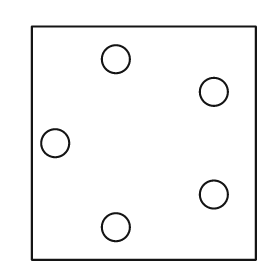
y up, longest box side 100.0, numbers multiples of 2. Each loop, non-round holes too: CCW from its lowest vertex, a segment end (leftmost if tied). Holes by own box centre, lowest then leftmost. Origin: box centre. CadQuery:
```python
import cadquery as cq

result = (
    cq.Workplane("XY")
    .moveTo(-48.0, -50.0)
    .lineTo(48.0, -50.0)
    .lineTo(48.0, 50.0)
    .lineTo(-48.0, 50.0)
    .close()
    .moveTo(-12.0, -36.0)
    .circle(6.0)
    .moveTo(30.0, -22.0)
    .circle(6.0)
    .moveTo(-38.0, 0.0)
    .circle(6.0)
    .moveTo(30.0, 22.0)
    .circle(6.0)
    .moveTo(-12.0, 36.0)
    .circle(6.0)
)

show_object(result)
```